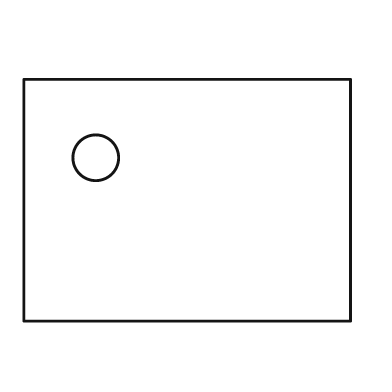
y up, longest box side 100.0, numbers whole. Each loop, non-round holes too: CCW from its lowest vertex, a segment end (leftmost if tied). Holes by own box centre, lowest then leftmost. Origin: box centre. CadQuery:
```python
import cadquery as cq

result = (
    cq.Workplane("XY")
    .moveTo(-50.0, -37.0)
    .lineTo(50.0, -37.0)
    .lineTo(50.0, 37.0)
    .lineTo(-50.0, 37.0)
    .close()
    .moveTo(-28.0, 13.0)
    .circle(7.0)
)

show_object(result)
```